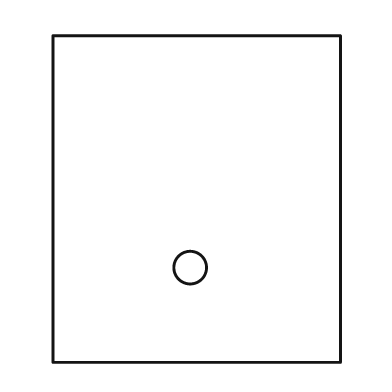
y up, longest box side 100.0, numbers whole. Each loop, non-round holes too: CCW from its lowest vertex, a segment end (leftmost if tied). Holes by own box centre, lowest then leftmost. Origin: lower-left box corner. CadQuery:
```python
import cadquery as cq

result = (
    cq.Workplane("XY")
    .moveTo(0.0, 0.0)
    .lineTo(88.0, 0.0)
    .lineTo(88.0, 100.0)
    .lineTo(0.0, 100.0)
    .close()
    .moveTo(42.0, 29.0)
    .circle(5.0)
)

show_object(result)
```